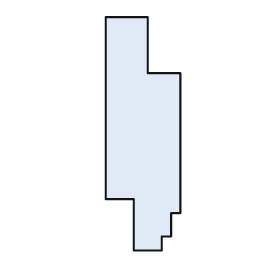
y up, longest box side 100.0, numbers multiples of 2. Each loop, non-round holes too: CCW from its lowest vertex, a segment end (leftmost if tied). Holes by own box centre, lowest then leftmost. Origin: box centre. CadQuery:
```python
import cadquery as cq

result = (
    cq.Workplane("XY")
    .moveTo(-4.0, -50.0)
    .lineTo(8.0, -50.0)
    .lineTo(8.0, -44.0)
    .lineTo(12.0, -44.0)
    .lineTo(12.0, -34.0)
    .lineTo(16.0, -34.0)
    .lineTo(16.0, 26.0)
    .lineTo(2.0, 26.0)
    .lineTo(2.0, 50.0)
    .lineTo(-16.0, 50.0)
    .lineTo(-16.0, -28.0)
    .lineTo(-4.0, -28.0)
    .close()
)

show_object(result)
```